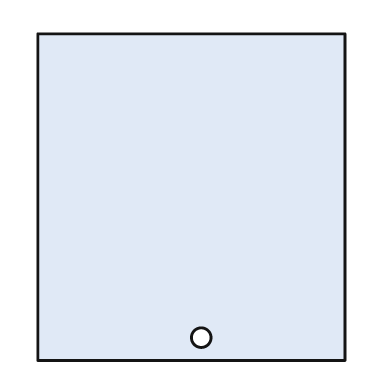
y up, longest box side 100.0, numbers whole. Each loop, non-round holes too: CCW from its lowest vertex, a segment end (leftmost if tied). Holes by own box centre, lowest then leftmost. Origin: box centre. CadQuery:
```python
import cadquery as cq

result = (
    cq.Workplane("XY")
    .moveTo(-47.0, -50.0)
    .lineTo(47.0, -50.0)
    .lineTo(47.0, 50.0)
    .lineTo(-47.0, 50.0)
    .close()
    .moveTo(3.0, -43.0)
    .circle(3.0)
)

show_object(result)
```